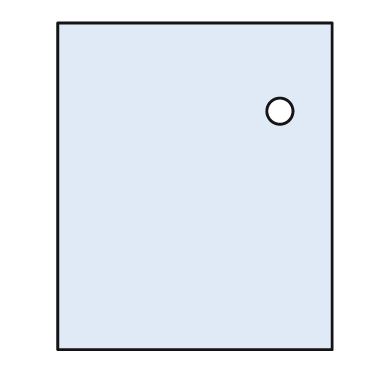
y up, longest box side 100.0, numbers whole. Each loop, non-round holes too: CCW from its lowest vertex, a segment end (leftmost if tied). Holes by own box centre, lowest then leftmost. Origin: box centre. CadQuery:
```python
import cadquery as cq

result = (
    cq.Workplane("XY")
    .moveTo(-42.0, -50.0)
    .lineTo(42.0, -50.0)
    .lineTo(42.0, 50.0)
    .lineTo(-42.0, 50.0)
    .close()
    .moveTo(26.0, 23.0)
    .circle(4.0)
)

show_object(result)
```